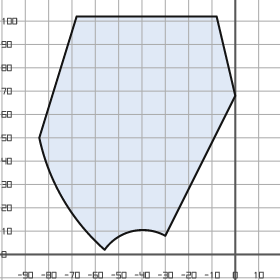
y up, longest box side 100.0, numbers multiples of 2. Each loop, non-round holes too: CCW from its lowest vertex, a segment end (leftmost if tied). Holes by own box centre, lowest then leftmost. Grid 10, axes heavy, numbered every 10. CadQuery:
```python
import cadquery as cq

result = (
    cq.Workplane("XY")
    .moveTo(-56.0, 2.0)
    .threePointArc((-44.0, 10.0), (-30.0, 8.0))
    .lineTo(0.0, 68.0)
    .lineTo(-8.0, 102.0)
    .lineTo(-68.0, 102.0)
    .lineTo(-84.0, 50.0)
    .threePointArc((-74.0, 24.0), (-56.0, 2.0))
    .close()
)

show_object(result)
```